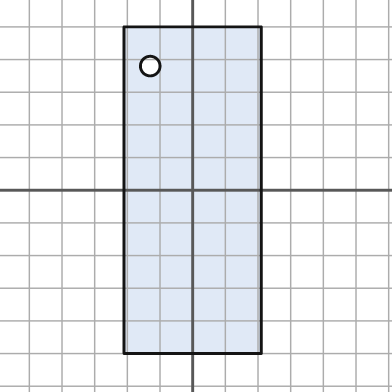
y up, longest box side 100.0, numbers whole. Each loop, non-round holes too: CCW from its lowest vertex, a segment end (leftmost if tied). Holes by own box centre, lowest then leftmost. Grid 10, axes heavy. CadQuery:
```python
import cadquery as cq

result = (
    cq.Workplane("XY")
    .moveTo(-21.0, -50.0)
    .lineTo(21.0, -50.0)
    .lineTo(21.0, 50.0)
    .lineTo(-21.0, 50.0)
    .close()
    .moveTo(-13.0, 38.0)
    .circle(3.0)
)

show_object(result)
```